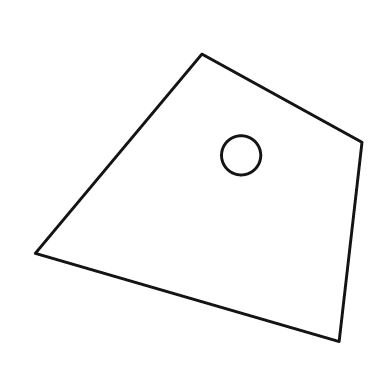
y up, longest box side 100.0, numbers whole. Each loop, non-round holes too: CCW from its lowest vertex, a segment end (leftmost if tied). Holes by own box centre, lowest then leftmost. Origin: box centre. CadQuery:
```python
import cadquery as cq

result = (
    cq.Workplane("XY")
    .moveTo(43.0, -44.0)
    .lineTo(50.0, 17.0)
    .lineTo(1.0, 44.0)
    .lineTo(-50.0, -17.0)
    .close()
    .moveTo(13.0, 13.0)
    .circle(6.0)
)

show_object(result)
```